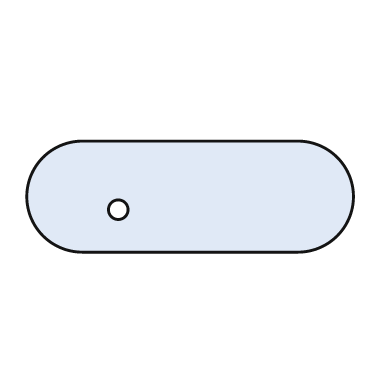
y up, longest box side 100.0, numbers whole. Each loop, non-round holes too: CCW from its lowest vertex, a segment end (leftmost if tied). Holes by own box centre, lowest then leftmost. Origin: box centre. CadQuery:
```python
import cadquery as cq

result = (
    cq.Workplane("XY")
    .moveTo(-33.0, -17.0)
    .lineTo(33.0, -17.0)
    .threePointArc((50.0, 0.0), (33.0, 17.0))
    .lineTo(-33.0, 17.0)
    .threePointArc((-50.0, 0.0), (-33.0, -17.0))
    .close()
    .moveTo(-22.0, -4.0)
    .circle(3.0)
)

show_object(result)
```